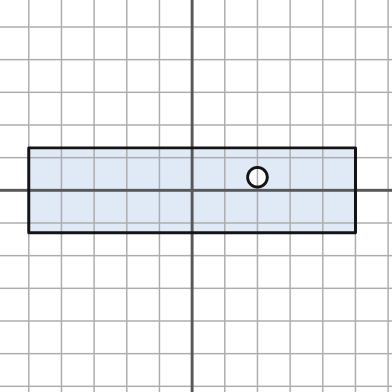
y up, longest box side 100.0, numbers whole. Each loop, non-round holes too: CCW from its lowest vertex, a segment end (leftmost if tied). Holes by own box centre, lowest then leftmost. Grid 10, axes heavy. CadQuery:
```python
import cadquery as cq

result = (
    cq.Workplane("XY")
    .moveTo(-50.0, -13.0)
    .lineTo(50.0, -13.0)
    .lineTo(50.0, 13.0)
    .lineTo(-50.0, 13.0)
    .close()
    .moveTo(20.0, 4.0)
    .circle(3.0)
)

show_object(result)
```